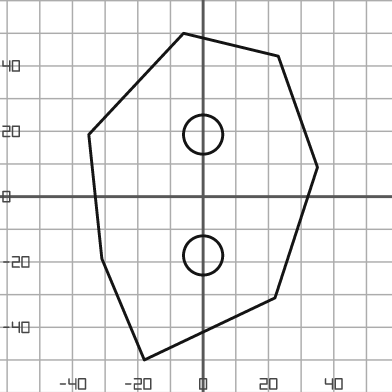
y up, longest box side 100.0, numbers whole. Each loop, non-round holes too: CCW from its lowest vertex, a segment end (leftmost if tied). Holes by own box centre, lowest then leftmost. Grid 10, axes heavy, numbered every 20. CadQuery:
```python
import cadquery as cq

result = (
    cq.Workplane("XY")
    .moveTo(-18.0, -50.0)
    .lineTo(22.0, -31.0)
    .lineTo(35.0, 9.0)
    .lineTo(23.0, 43.0)
    .lineTo(-6.0, 50.0)
    .lineTo(-35.0, 19.0)
    .lineTo(-31.0, -19.0)
    .close()
    .moveTo(0.0, -18.0)
    .circle(6.0)
    .moveTo(0.0, 19.0)
    .circle(6.0)
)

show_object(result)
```